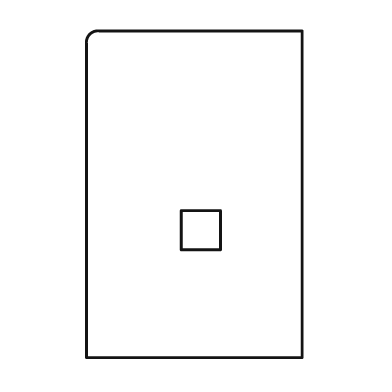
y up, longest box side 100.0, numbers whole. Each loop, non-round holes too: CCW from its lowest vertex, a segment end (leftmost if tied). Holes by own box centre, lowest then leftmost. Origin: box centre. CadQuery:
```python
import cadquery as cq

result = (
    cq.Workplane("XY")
    .moveTo(-33.0, -50.0)
    .lineTo(33.0, -50.0)
    .lineTo(33.0, 50.0)
    .lineTo(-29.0, 50.0)
    .threePointArc((-32.0, 49.0), (-33.0, 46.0))
    .close()
    .moveTo(-4.0, -17.0)
    .lineTo(8.0, -17.0)
    .lineTo(8.0, -5.0)
    .lineTo(-4.0, -5.0)
    .close()
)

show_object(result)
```